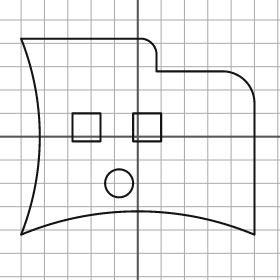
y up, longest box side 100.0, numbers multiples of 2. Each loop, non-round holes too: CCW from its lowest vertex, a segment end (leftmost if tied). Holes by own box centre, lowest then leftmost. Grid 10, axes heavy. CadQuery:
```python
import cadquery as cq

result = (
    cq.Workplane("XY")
    .moveTo(-50.0, -42.0)
    .threePointArc((0.0, -32.0), (50.0, -42.0))
    .lineTo(50.0, 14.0)
    .threePointArc((46.0, 24.0), (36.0, 28.0))
    .lineTo(8.0, 28.0)
    .lineTo(8.0, 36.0)
    .threePointArc((6.0, 40.0), (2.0, 42.0))
    .lineTo(-50.0, 42.0)
    .threePointArc((-42.0, 0.0), (-50.0, -42.0))
    .close()
    .moveTo(-8.0, -20.0)
    .circle(6.0)
    .moveTo(-28.0, -2.0)
    .lineTo(-16.0, -2.0)
    .lineTo(-16.0, 10.0)
    .lineTo(-28.0, 10.0)
    .close()
    .moveTo(-2.0, -2.0)
    .lineTo(10.0, -2.0)
    .lineTo(10.0, 10.0)
    .lineTo(-2.0, 10.0)
    .close()
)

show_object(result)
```